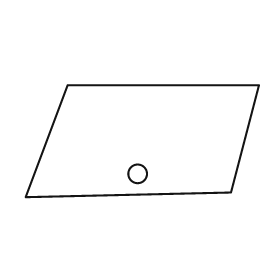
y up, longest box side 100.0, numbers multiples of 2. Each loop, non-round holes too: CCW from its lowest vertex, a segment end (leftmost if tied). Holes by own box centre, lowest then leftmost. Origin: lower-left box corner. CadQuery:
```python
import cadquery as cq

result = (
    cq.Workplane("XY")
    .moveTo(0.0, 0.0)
    .lineTo(88.0, 2.0)
    .lineTo(100.0, 48.0)
    .lineTo(18.0, 48.0)
    .close()
    .moveTo(48.0, 10.0)
    .circle(4.0)
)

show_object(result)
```